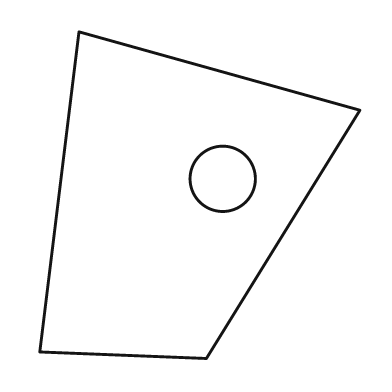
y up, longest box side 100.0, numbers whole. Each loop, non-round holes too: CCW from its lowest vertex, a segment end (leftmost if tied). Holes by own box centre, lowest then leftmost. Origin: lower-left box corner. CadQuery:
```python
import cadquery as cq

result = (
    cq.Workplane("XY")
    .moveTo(51.0, 0.0)
    .lineTo(98.0, 76.0)
    .lineTo(12.0, 100.0)
    .lineTo(0.0, 2.0)
    .close()
    .moveTo(56.0, 55.0)
    .circle(10.0)
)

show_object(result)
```